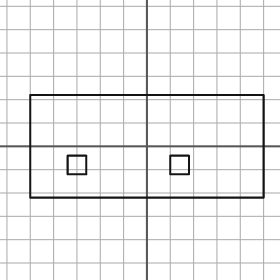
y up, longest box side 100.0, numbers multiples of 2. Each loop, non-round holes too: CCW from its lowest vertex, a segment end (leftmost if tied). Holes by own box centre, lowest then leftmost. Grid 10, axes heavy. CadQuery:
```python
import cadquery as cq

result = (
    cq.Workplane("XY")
    .moveTo(-50.0, -22.0)
    .lineTo(50.0, -22.0)
    .lineTo(50.0, 22.0)
    .lineTo(-50.0, 22.0)
    .close()
    .moveTo(-34.0, -12.0)
    .lineTo(-26.0, -12.0)
    .lineTo(-26.0, -4.0)
    .lineTo(-34.0, -4.0)
    .close()
    .moveTo(10.0, -12.0)
    .lineTo(18.0, -12.0)
    .lineTo(18.0, -4.0)
    .lineTo(10.0, -4.0)
    .close()
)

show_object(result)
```